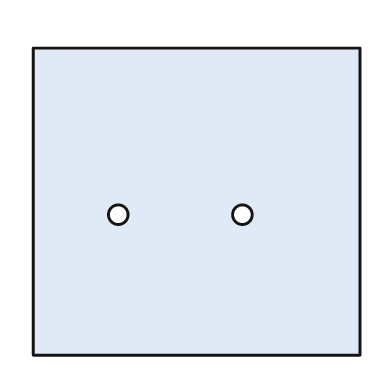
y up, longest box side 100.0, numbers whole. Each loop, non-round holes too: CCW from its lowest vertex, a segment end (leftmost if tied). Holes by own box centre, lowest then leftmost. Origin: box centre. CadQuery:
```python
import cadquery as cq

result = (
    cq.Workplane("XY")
    .moveTo(-50.0, -47.0)
    .lineTo(50.0, -47.0)
    .lineTo(50.0, 47.0)
    .lineTo(-50.0, 47.0)
    .close()
    .moveTo(-24.0, -4.0)
    .circle(3.0)
    .moveTo(14.0, -4.0)
    .circle(3.0)
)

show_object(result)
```